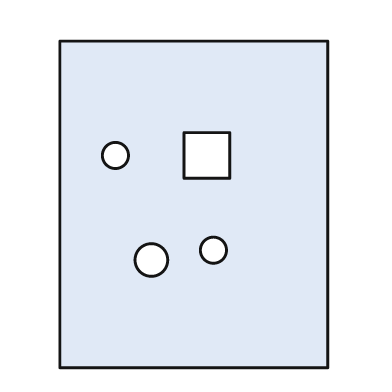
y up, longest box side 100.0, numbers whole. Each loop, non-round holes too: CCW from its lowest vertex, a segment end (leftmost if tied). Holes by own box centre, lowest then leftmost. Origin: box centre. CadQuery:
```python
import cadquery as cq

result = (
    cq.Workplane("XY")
    .moveTo(-41.0, -50.0)
    .lineTo(41.0, -50.0)
    .lineTo(41.0, 50.0)
    .lineTo(-41.0, 50.0)
    .close()
    .moveTo(-13.0, -17.0)
    .circle(5.0)
    .moveTo(6.0, -14.0)
    .circle(4.0)
    .moveTo(-24.0, 15.0)
    .circle(4.0)
    .moveTo(-3.0, 8.0)
    .lineTo(11.0, 8.0)
    .lineTo(11.0, 22.0)
    .lineTo(-3.0, 22.0)
    .close()
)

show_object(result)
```